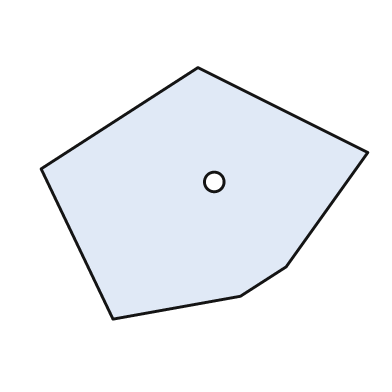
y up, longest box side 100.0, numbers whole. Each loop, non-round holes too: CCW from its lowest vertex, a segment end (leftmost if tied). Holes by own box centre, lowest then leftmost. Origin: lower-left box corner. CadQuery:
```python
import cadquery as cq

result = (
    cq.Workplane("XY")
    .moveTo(22.0, 0.0)
    .lineTo(61.0, 7.0)
    .lineTo(75.0, 16.0)
    .lineTo(100.0, 51.0)
    .lineTo(48.0, 77.0)
    .lineTo(0.0, 46.0)
    .close()
    .moveTo(53.0, 42.0)
    .circle(3.0)
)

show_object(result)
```